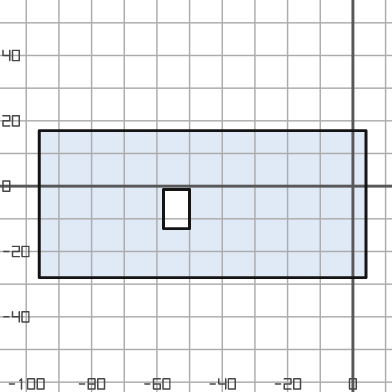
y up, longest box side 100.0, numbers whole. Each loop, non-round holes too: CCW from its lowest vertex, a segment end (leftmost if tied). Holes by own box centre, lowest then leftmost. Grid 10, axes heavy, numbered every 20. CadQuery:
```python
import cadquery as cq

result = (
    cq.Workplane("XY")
    .moveTo(-96.0, -28.0)
    .lineTo(4.0, -28.0)
    .lineTo(4.0, 17.0)
    .lineTo(-96.0, 17.0)
    .close()
    .moveTo(-58.0, -13.0)
    .lineTo(-50.0, -13.0)
    .lineTo(-50.0, -1.0)
    .lineTo(-58.0, -1.0)
    .close()
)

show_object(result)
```